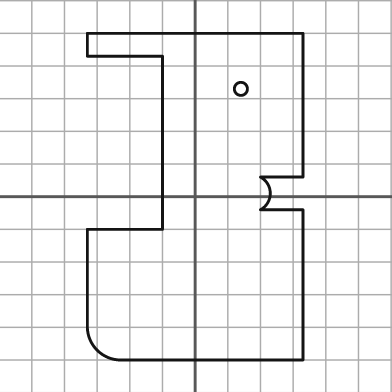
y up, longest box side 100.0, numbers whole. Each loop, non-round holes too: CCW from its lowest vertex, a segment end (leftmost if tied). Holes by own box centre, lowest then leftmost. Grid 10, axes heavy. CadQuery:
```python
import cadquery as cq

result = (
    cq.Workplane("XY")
    .moveTo(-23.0, -50.0)
    .lineTo(33.0, -50.0)
    .lineTo(33.0, -4.0)
    .lineTo(20.0, -4.0)
    .threePointArc((23.0, 1.0), (20.0, 6.0))
    .lineTo(33.0, 6.0)
    .lineTo(33.0, 50.0)
    .lineTo(-33.0, 50.0)
    .lineTo(-33.0, 43.0)
    .lineTo(-10.0, 43.0)
    .lineTo(-10.0, -10.0)
    .lineTo(-33.0, -10.0)
    .lineTo(-33.0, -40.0)
    .threePointArc((-30.0, -47.0), (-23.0, -50.0))
    .close()
    .moveTo(14.0, 33.0)
    .circle(2.0)
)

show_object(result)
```